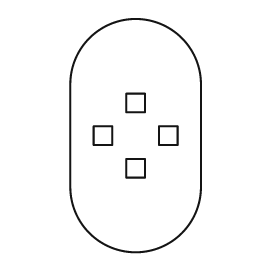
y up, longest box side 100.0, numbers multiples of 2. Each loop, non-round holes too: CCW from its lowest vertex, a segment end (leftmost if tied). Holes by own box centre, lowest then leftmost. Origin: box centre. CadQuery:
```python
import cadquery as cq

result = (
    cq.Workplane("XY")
    .moveTo(-28.0, -22.0)
    .threePointArc((0.0, -50.0), (28.0, -22.0))
    .lineTo(28.0, 22.0)
    .threePointArc((0.0, 50.0), (-28.0, 22.0))
    .close()
    .moveTo(-4.0, -18.0)
    .lineTo(4.0, -18.0)
    .lineTo(4.0, -10.0)
    .lineTo(-4.0, -10.0)
    .close()
    .moveTo(-18.0, -4.0)
    .lineTo(-10.0, -4.0)
    .lineTo(-10.0, 4.0)
    .lineTo(-18.0, 4.0)
    .close()
    .moveTo(10.0, -4.0)
    .lineTo(18.0, -4.0)
    .lineTo(18.0, 4.0)
    .lineTo(10.0, 4.0)
    .close()
    .moveTo(-4.0, 10.0)
    .lineTo(4.0, 10.0)
    .lineTo(4.0, 18.0)
    .lineTo(-4.0, 18.0)
    .close()
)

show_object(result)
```